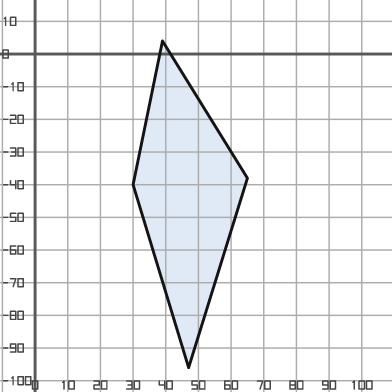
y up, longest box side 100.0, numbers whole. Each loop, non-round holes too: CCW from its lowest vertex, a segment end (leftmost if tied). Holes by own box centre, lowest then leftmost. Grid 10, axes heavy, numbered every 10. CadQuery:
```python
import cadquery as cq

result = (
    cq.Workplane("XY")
    .moveTo(47.0, -96.0)
    .lineTo(65.0, -38.0)
    .lineTo(39.0, 4.0)
    .lineTo(30.0, -40.0)
    .close()
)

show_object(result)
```